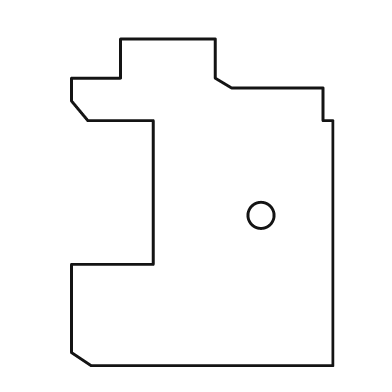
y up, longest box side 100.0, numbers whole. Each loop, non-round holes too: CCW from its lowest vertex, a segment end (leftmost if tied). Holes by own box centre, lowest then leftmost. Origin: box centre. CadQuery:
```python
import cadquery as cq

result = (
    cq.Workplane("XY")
    .moveTo(-34.0, -50.0)
    .lineTo(40.0, -50.0)
    .lineTo(40.0, 25.0)
    .lineTo(37.0, 25.0)
    .lineTo(37.0, 35.0)
    .lineTo(9.0, 35.0)
    .lineTo(4.0, 38.0)
    .lineTo(4.0, 50.0)
    .lineTo(-25.0, 50.0)
    .lineTo(-25.0, 38.0)
    .lineTo(-40.0, 38.0)
    .lineTo(-40.0, 31.0)
    .lineTo(-35.0, 25.0)
    .lineTo(-15.0, 25.0)
    .lineTo(-15.0, -19.0)
    .lineTo(-40.0, -19.0)
    .lineTo(-40.0, -46.0)
    .close()
    .moveTo(18.0, -4.0)
    .circle(4.0)
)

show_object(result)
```